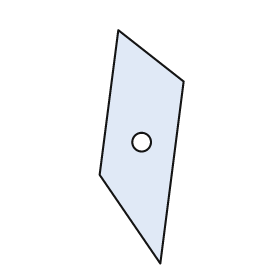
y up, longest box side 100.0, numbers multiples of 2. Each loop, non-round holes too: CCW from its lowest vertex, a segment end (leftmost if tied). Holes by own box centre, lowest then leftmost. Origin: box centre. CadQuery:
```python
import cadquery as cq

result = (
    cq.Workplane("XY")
    .moveTo(8.0, -50.0)
    .lineTo(18.0, 28.0)
    .lineTo(-10.0, 50.0)
    .lineTo(-18.0, -12.0)
    .close()
    .moveTo(0.0, 2.0)
    .circle(4.0)
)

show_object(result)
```